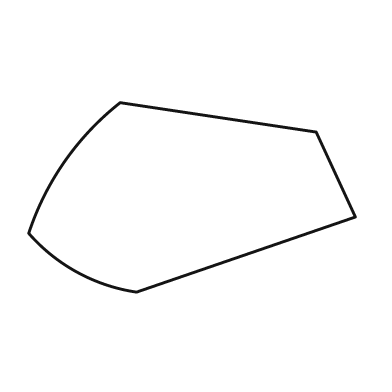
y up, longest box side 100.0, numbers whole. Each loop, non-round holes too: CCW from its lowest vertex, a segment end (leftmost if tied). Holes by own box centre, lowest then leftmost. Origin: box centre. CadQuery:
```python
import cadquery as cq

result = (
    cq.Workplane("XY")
    .moveTo(-17.0, -29.0)
    .lineTo(50.0, -6.0)
    .lineTo(38.0, 20.0)
    .lineTo(-22.0, 29.0)
    .threePointArc((-39.0, 11.0), (-50.0, -11.0))
    .threePointArc((-35.0, -23.0), (-17.0, -29.0))
    .close()
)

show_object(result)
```